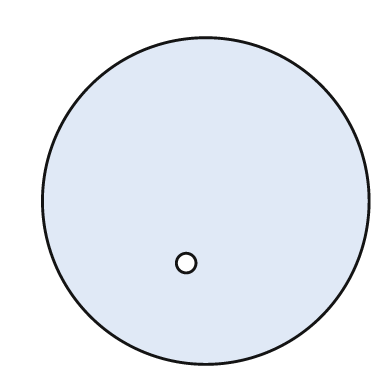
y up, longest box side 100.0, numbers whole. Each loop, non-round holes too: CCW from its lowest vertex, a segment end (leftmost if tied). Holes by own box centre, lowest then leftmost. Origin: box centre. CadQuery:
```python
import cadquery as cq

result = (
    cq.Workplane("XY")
    .moveTo(0.0, 0.0)
    .circle(50.0)
    .moveTo(-6.0, -19.0)
    .circle(3.0)
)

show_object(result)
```